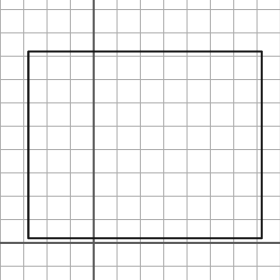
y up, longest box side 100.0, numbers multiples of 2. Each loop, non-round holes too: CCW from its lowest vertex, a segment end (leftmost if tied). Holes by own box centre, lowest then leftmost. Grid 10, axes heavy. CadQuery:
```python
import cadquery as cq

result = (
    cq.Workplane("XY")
    .moveTo(-28.0, 2.0)
    .lineTo(72.0, 2.0)
    .lineTo(72.0, 82.0)
    .lineTo(-28.0, 82.0)
    .close()
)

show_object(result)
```